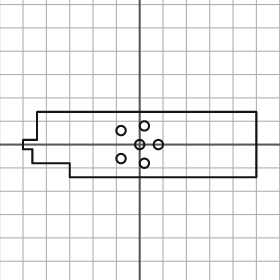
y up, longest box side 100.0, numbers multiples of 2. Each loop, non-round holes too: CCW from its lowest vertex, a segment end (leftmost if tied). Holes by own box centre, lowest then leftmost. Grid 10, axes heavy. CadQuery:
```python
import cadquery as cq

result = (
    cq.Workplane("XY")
    .moveTo(-30.0, -14.0)
    .lineTo(50.0, -14.0)
    .lineTo(50.0, 14.0)
    .lineTo(-44.0, 14.0)
    .lineTo(-44.0, 2.0)
    .lineTo(-50.0, 2.0)
    .lineTo(-50.0, -2.0)
    .lineTo(-46.0, -2.0)
    .lineTo(-46.0, -8.0)
    .lineTo(-30.0, -8.0)
    .close()
    .moveTo(2.0, -8.0)
    .circle(2.0)
    .moveTo(-8.0, -6.0)
    .circle(2.0)
    .moveTo(0.0, 0.0)
    .circle(2.0)
    .moveTo(8.0, 0.0)
    .circle(2.0)
    .moveTo(-8.0, 6.0)
    .circle(2.0)
    .moveTo(2.0, 8.0)
    .circle(2.0)
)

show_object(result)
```